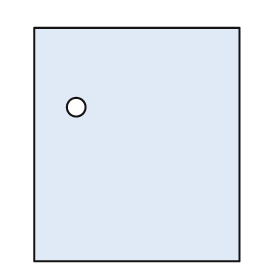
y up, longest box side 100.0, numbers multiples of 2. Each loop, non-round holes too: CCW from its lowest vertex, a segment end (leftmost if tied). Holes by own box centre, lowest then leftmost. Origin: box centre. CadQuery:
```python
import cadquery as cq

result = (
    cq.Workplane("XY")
    .moveTo(-44.0, -50.0)
    .lineTo(44.0, -50.0)
    .lineTo(44.0, 50.0)
    .lineTo(-44.0, 50.0)
    .close()
    .moveTo(-26.0, 16.0)
    .circle(4.0)
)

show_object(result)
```